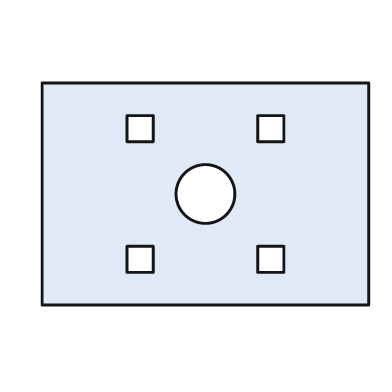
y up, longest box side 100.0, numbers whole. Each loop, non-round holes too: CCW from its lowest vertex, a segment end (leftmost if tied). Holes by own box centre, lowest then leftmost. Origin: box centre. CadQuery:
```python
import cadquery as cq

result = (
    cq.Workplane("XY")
    .moveTo(-50.0, -34.0)
    .lineTo(50.0, -34.0)
    .lineTo(50.0, 34.0)
    .lineTo(-50.0, 34.0)
    .close()
    .moveTo(-24.0, -24.0)
    .lineTo(-16.0, -24.0)
    .lineTo(-16.0, -16.0)
    .lineTo(-24.0, -16.0)
    .close()
    .moveTo(16.0, -24.0)
    .lineTo(24.0, -24.0)
    .lineTo(24.0, -16.0)
    .lineTo(16.0, -16.0)
    .close()
    .moveTo(0.0, 0.0)
    .circle(9.0)
    .moveTo(-24.0, 16.0)
    .lineTo(-16.0, 16.0)
    .lineTo(-16.0, 24.0)
    .lineTo(-24.0, 24.0)
    .close()
    .moveTo(16.0, 16.0)
    .lineTo(24.0, 16.0)
    .lineTo(24.0, 24.0)
    .lineTo(16.0, 24.0)
    .close()
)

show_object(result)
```